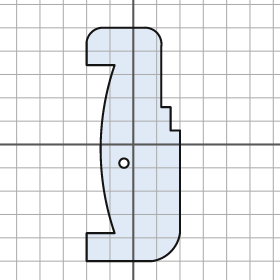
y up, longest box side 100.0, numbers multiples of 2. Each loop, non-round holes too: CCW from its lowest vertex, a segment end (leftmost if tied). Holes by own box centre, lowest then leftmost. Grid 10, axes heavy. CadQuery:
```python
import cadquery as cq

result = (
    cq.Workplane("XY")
    .moveTo(-20.0, -50.0)
    .lineTo(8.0, -50.0)
    .threePointArc((16.0, -46.0), (20.0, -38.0))
    .lineTo(20.0, 6.0)
    .lineTo(16.0, 6.0)
    .lineTo(16.0, 16.0)
    .lineTo(12.0, 16.0)
    .lineTo(12.0, 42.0)
    .threePointArc((10.0, 48.0), (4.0, 50.0))
    .lineTo(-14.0, 50.0)
    .threePointArc((-18.0, 48.0), (-20.0, 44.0))
    .lineTo(-20.0, 34.0)
    .lineTo(-8.0, 34.0)
    .threePointArc((-14.0, -2.0), (-8.0, -38.0))
    .lineTo(-20.0, -38.0)
    .close()
    .moveTo(-4.0, -8.0)
    .circle(2.0)
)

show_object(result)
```